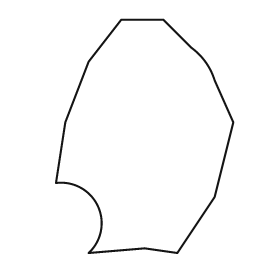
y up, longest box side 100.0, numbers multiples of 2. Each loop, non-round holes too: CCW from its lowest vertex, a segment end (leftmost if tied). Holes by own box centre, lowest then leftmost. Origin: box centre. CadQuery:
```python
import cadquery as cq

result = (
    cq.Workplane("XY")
    .moveTo(-24.0, -50.0)
    .lineTo(0.0, -48.0)
    .lineTo(14.0, -50.0)
    .lineTo(30.0, -26.0)
    .lineTo(38.0, 6.0)
    .lineTo(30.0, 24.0)
    .threePointArc((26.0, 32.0), (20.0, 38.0))
    .lineTo(8.0, 50.0)
    .lineTo(-10.0, 50.0)
    .lineTo(-24.0, 32.0)
    .lineTo(-34.0, 6.0)
    .lineTo(-38.0, -20.0)
    .threePointArc((-20.0, -30.0), (-24.0, -50.0))
    .close()
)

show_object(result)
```